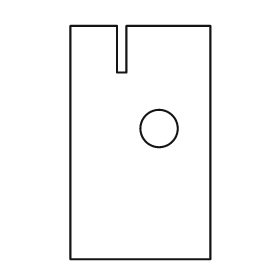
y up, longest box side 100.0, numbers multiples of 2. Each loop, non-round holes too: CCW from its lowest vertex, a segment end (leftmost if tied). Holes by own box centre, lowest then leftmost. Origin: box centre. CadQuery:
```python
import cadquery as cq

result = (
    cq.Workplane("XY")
    .moveTo(-30.0, -50.0)
    .lineTo(30.0, -50.0)
    .lineTo(30.0, 50.0)
    .lineTo(-6.0, 50.0)
    .lineTo(-6.0, 30.0)
    .lineTo(-10.0, 30.0)
    .lineTo(-10.0, 50.0)
    .lineTo(-30.0, 50.0)
    .close()
    .moveTo(8.0, 6.0)
    .circle(8.0)
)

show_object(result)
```